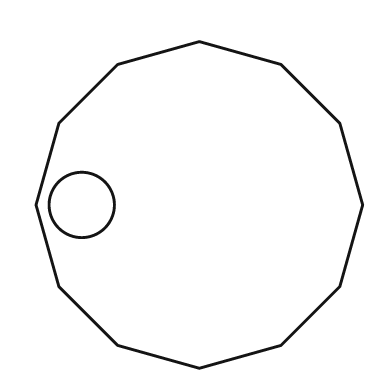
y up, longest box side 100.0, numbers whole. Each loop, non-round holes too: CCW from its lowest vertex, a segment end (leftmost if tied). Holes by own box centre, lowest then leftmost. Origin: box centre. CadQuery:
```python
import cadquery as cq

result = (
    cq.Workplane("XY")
    .moveTo(0.0, -50.0)
    .lineTo(25.0, -43.0)
    .lineTo(43.0, -25.0)
    .lineTo(50.0, 0.0)
    .lineTo(43.0, 25.0)
    .lineTo(25.0, 43.0)
    .lineTo(0.0, 50.0)
    .lineTo(-25.0, 43.0)
    .lineTo(-43.0, 25.0)
    .lineTo(-50.0, 0.0)
    .lineTo(-43.0, -25.0)
    .lineTo(-25.0, -43.0)
    .close()
    .moveTo(-36.0, 0.0)
    .circle(10.0)
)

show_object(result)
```